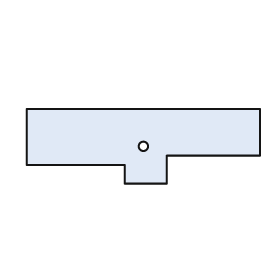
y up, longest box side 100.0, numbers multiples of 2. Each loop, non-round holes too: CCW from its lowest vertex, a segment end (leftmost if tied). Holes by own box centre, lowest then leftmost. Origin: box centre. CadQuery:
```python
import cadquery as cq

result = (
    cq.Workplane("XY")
    .moveTo(-8.0, -16.0)
    .lineTo(10.0, -16.0)
    .lineTo(10.0, -4.0)
    .lineTo(50.0, -4.0)
    .lineTo(50.0, 16.0)
    .lineTo(-50.0, 16.0)
    .lineTo(-50.0, -8.0)
    .lineTo(-8.0, -8.0)
    .close()
    .moveTo(0.0, 0.0)
    .circle(2.0)
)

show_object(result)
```